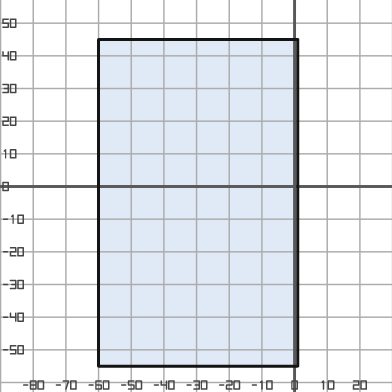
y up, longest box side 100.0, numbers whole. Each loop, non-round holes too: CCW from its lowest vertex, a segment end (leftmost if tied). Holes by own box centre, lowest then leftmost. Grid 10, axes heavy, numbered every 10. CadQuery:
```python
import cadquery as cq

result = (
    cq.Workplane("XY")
    .moveTo(-60.0, -55.0)
    .lineTo(1.0, -55.0)
    .lineTo(1.0, 45.0)
    .lineTo(-60.0, 45.0)
    .close()
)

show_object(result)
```